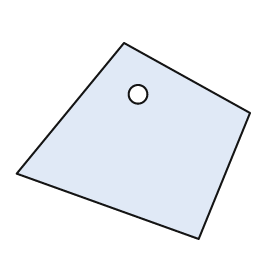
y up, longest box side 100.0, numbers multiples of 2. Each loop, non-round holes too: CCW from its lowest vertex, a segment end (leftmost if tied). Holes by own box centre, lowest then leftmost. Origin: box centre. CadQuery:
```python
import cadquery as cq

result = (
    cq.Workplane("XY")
    .moveTo(28.0, -42.0)
    .lineTo(50.0, 12.0)
    .lineTo(-4.0, 42.0)
    .lineTo(-50.0, -14.0)
    .close()
    .moveTo(2.0, 20.0)
    .circle(4.0)
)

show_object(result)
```